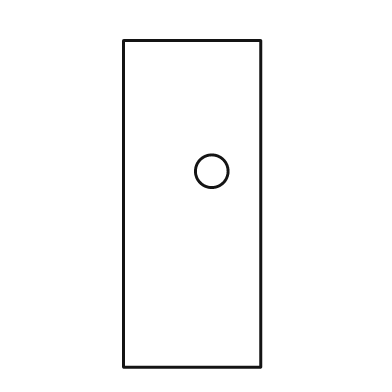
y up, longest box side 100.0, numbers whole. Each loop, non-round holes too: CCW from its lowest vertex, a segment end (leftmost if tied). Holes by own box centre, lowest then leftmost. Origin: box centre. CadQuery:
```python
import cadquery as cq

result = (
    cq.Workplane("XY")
    .moveTo(-21.0, -50.0)
    .lineTo(21.0, -50.0)
    .lineTo(21.0, 50.0)
    .lineTo(-21.0, 50.0)
    .close()
    .moveTo(6.0, 10.0)
    .circle(5.0)
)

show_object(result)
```